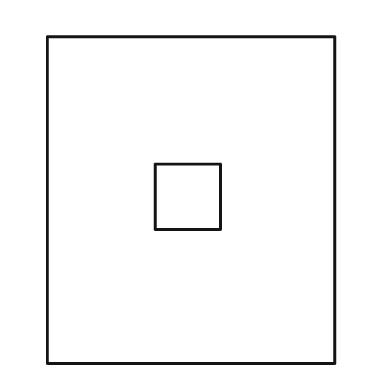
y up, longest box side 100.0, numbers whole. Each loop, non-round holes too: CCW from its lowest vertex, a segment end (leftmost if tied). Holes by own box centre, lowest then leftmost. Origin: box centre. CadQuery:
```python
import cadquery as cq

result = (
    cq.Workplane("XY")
    .moveTo(-44.0, -50.0)
    .lineTo(44.0, -50.0)
    .lineTo(44.0, 50.0)
    .lineTo(-44.0, 50.0)
    .close()
    .moveTo(-11.0, -9.0)
    .lineTo(9.0, -9.0)
    .lineTo(9.0, 11.0)
    .lineTo(-11.0, 11.0)
    .close()
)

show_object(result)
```